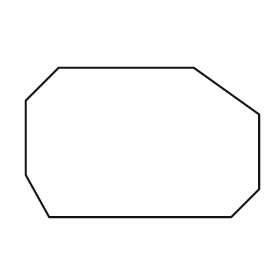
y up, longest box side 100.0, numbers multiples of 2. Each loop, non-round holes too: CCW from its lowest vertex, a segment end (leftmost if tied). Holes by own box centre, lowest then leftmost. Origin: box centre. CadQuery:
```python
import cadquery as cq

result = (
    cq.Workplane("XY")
    .moveTo(-40.0, -32.0)
    .lineTo(38.0, -32.0)
    .lineTo(50.0, -20.0)
    .lineTo(50.0, 12.0)
    .lineTo(22.0, 32.0)
    .lineTo(-36.0, 32.0)
    .lineTo(-50.0, 18.0)
    .lineTo(-50.0, -14.0)
    .close()
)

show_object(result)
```